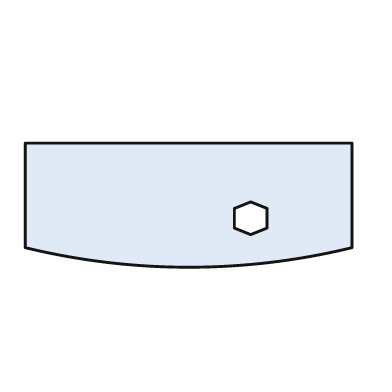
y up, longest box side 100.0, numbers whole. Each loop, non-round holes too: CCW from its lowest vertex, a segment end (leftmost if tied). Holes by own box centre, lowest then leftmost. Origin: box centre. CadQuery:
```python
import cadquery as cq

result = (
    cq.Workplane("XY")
    .moveTo(-50.0, -13.0)
    .threePointArc((0.0, -19.0), (50.0, -13.0))
    .lineTo(50.0, 19.0)
    .lineTo(-50.0, 19.0)
    .close()
    .moveTo(19.0, -9.0)
    .lineTo(24.0, -7.0)
    .lineTo(24.0, -1.0)
    .lineTo(19.0, 1.0)
    .lineTo(14.0, -1.0)
    .lineTo(14.0, -7.0)
    .close()
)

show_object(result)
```